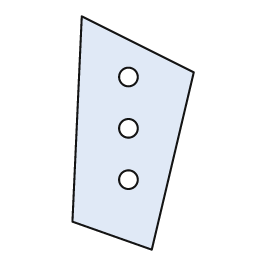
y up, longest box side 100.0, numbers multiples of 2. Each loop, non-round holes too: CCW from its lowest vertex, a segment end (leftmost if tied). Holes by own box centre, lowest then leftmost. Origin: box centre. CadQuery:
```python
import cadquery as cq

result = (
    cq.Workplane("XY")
    .moveTo(8.0, -50.0)
    .lineTo(26.0, 26.0)
    .lineTo(-22.0, 50.0)
    .lineTo(-26.0, -38.0)
    .close()
    .moveTo(-2.0, -20.0)
    .circle(4.0)
    .moveTo(-2.0, 2.0)
    .circle(4.0)
    .moveTo(-2.0, 24.0)
    .circle(4.0)
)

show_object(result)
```